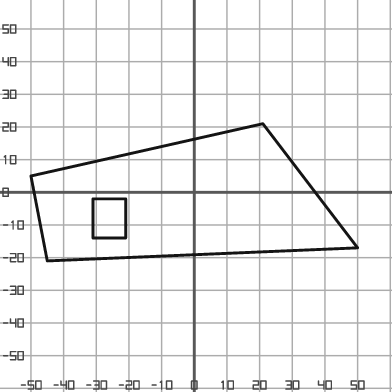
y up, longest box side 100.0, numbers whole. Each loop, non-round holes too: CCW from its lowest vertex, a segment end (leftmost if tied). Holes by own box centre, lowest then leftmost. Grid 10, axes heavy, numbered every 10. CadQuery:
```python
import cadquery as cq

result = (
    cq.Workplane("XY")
    .moveTo(-45.0, -21.0)
    .lineTo(50.0, -17.0)
    .lineTo(21.0, 21.0)
    .lineTo(-50.0, 5.0)
    .close()
    .moveTo(-31.0, -14.0)
    .lineTo(-21.0, -14.0)
    .lineTo(-21.0, -2.0)
    .lineTo(-31.0, -2.0)
    .close()
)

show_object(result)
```